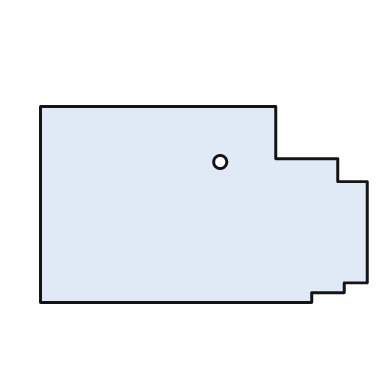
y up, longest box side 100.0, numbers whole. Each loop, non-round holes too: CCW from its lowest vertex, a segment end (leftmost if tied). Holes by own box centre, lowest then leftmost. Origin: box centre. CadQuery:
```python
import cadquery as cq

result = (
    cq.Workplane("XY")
    .moveTo(-50.0, -30.0)
    .lineTo(33.0, -30.0)
    .lineTo(33.0, -27.0)
    .lineTo(43.0, -27.0)
    .lineTo(43.0, -24.0)
    .lineTo(50.0, -24.0)
    .lineTo(50.0, 7.0)
    .lineTo(41.0, 7.0)
    .lineTo(41.0, 14.0)
    .lineTo(22.0, 14.0)
    .lineTo(22.0, 30.0)
    .lineTo(-50.0, 30.0)
    .close()
    .moveTo(5.0, 13.0)
    .circle(2.0)
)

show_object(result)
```